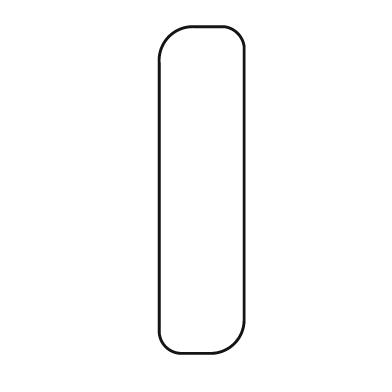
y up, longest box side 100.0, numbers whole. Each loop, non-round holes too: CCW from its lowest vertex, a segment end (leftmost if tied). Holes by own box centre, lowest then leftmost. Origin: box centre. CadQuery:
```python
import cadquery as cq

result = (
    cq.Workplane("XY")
    .moveTo(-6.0, -50.0)
    .lineTo(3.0, -50.0)
    .threePointArc((10.0, -47.0), (13.0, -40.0))
    .lineTo(13.0, 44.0)
    .threePointArc((11.0, 48.0), (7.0, 50.0))
    .lineTo(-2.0, 50.0)
    .threePointArc((-10.0, 47.0), (-13.0, 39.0))
    .lineTo(-13.0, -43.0)
    .threePointArc((-11.0, -48.0), (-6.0, -50.0))
    .close()
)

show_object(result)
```